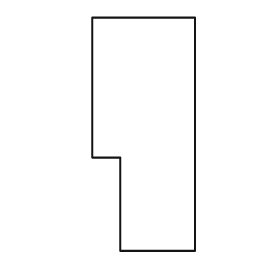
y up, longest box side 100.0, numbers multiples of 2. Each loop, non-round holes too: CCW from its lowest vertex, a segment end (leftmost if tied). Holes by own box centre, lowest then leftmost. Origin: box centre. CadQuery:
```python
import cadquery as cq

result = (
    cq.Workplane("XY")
    .moveTo(-10.0, -50.0)
    .lineTo(22.0, -50.0)
    .lineTo(22.0, 50.0)
    .lineTo(-22.0, 50.0)
    .lineTo(-22.0, -10.0)
    .lineTo(-10.0, -10.0)
    .close()
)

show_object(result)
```